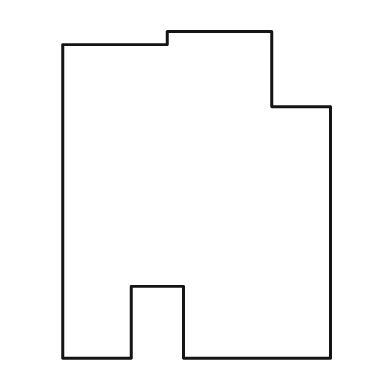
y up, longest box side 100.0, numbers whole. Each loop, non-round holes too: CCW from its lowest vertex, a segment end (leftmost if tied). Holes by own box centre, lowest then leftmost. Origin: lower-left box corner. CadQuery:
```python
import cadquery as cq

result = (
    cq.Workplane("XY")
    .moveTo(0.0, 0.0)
    .lineTo(21.0, 0.0)
    .lineTo(21.0, 22.0)
    .lineTo(37.0, 22.0)
    .lineTo(37.0, 0.0)
    .lineTo(82.0, 0.0)
    .lineTo(82.0, 77.0)
    .lineTo(64.0, 77.0)
    .lineTo(64.0, 100.0)
    .lineTo(32.0, 100.0)
    .lineTo(32.0, 96.0)
    .lineTo(0.0, 96.0)
    .close()
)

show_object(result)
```